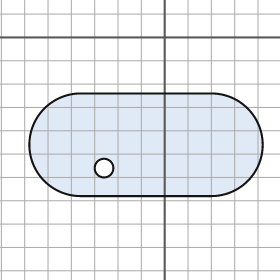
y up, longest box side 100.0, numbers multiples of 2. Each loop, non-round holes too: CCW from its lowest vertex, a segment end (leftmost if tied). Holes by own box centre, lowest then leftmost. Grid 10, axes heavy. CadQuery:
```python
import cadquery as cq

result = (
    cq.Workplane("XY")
    .moveTo(-36.0, -68.0)
    .lineTo(20.0, -68.0)
    .threePointArc((42.0, -46.0), (20.0, -24.0))
    .lineTo(-36.0, -24.0)
    .threePointArc((-58.0, -46.0), (-36.0, -68.0))
    .close()
    .moveTo(-26.0, -56.0)
    .circle(4.0)
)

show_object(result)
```